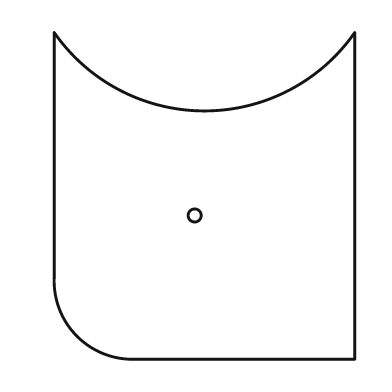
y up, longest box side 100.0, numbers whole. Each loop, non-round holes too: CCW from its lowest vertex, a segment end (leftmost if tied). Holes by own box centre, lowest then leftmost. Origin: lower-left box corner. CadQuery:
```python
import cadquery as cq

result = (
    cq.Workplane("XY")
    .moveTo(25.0, 0.0)
    .lineTo(92.0, 0.0)
    .lineTo(92.0, 100.0)
    .threePointArc((46.0, 76.0), (0.0, 100.0))
    .lineTo(0.0, 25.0)
    .threePointArc((7.0, 7.0), (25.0, 0.0))
    .close()
    .moveTo(43.0, 44.0)
    .circle(2.0)
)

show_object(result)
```